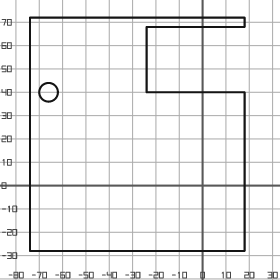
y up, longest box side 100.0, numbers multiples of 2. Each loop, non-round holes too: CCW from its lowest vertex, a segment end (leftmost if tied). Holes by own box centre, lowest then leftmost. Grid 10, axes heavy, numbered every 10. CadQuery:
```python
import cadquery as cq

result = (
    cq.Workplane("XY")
    .moveTo(-74.0, -28.0)
    .lineTo(18.0, -28.0)
    .lineTo(18.0, 40.0)
    .lineTo(-24.0, 40.0)
    .lineTo(-24.0, 68.0)
    .lineTo(18.0, 68.0)
    .lineTo(18.0, 72.0)
    .lineTo(-74.0, 72.0)
    .close()
    .moveTo(-66.0, 40.0)
    .circle(4.0)
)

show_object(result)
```